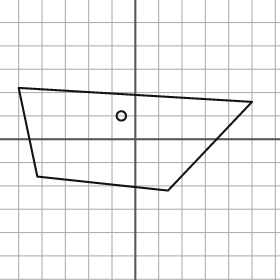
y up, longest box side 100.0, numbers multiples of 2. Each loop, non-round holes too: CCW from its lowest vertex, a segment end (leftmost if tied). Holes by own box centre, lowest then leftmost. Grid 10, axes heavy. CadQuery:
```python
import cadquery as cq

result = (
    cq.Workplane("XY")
    .moveTo(14.0, -22.0)
    .lineTo(50.0, 16.0)
    .lineTo(-50.0, 22.0)
    .lineTo(-42.0, -16.0)
    .close()
    .moveTo(-6.0, 10.0)
    .circle(2.0)
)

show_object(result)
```